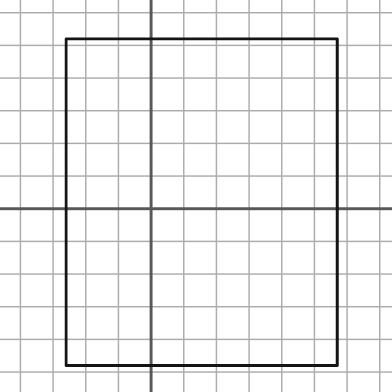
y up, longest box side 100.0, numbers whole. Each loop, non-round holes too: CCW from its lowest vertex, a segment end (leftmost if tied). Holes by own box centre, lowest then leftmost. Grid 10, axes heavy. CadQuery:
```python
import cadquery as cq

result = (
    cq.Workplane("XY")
    .moveTo(-26.0, -48.0)
    .lineTo(57.0, -48.0)
    .lineTo(57.0, 52.0)
    .lineTo(-26.0, 52.0)
    .close()
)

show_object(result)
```